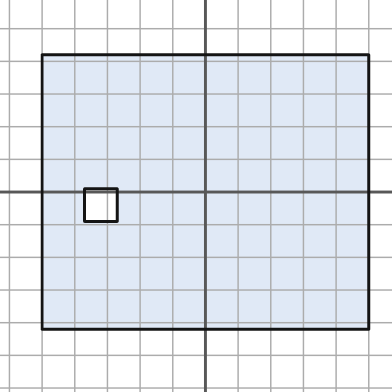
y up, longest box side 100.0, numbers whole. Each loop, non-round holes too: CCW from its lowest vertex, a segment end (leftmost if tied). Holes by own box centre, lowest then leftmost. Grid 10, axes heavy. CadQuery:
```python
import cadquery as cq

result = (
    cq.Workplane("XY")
    .moveTo(-50.0, -42.0)
    .lineTo(50.0, -42.0)
    .lineTo(50.0, 42.0)
    .lineTo(-50.0, 42.0)
    .close()
    .moveTo(-37.0, -9.0)
    .lineTo(-27.0, -9.0)
    .lineTo(-27.0, 1.0)
    .lineTo(-37.0, 1.0)
    .close()
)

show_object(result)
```